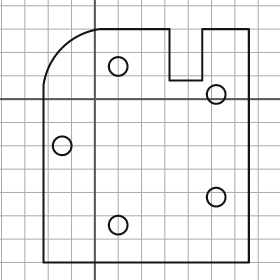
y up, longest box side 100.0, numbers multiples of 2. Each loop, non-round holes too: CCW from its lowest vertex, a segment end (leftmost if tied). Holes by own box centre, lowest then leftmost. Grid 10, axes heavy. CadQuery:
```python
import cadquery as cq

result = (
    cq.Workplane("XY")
    .moveTo(-22.0, -70.0)
    .lineTo(66.0, -70.0)
    .lineTo(66.0, 30.0)
    .lineTo(46.0, 30.0)
    .lineTo(46.0, 8.0)
    .lineTo(32.0, 8.0)
    .lineTo(32.0, 30.0)
    .lineTo(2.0, 30.0)
    .threePointArc((-14.0, 22.0), (-22.0, 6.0))
    .close()
    .moveTo(10.0, -54.0)
    .circle(4.0)
    .moveTo(52.0, -42.0)
    .circle(4.0)
    .moveTo(-14.0, -20.0)
    .circle(4.0)
    .moveTo(52.0, 2.0)
    .circle(4.0)
    .moveTo(10.0, 14.0)
    .circle(4.0)
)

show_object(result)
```